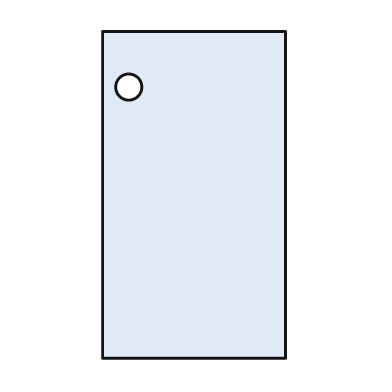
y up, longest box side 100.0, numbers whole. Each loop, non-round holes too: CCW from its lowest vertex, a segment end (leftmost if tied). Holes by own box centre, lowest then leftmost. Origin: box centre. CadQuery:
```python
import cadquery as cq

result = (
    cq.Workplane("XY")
    .moveTo(-28.0, -50.0)
    .lineTo(28.0, -50.0)
    .lineTo(28.0, 50.0)
    .lineTo(-28.0, 50.0)
    .close()
    .moveTo(-20.0, 33.0)
    .circle(4.0)
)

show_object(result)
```